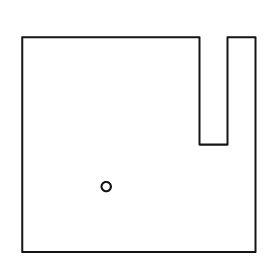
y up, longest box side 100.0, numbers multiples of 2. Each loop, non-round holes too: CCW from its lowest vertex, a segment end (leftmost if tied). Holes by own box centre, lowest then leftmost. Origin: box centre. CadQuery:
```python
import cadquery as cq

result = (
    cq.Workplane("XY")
    .moveTo(-50.0, -46.0)
    .lineTo(50.0, -46.0)
    .lineTo(50.0, 46.0)
    .lineTo(38.0, 46.0)
    .lineTo(38.0, 0.0)
    .lineTo(26.0, 0.0)
    .lineTo(26.0, 46.0)
    .lineTo(-50.0, 46.0)
    .close()
    .moveTo(-14.0, -18.0)
    .circle(2.0)
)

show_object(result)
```